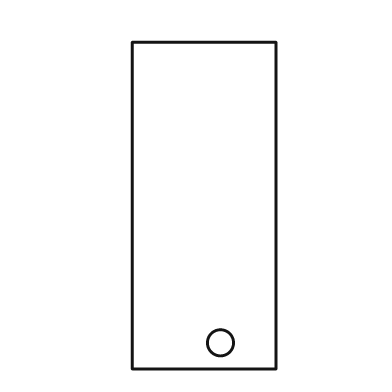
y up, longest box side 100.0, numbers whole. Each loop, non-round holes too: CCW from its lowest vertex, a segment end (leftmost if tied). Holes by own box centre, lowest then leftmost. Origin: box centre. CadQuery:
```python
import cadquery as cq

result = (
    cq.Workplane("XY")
    .moveTo(-22.0, -50.0)
    .lineTo(22.0, -50.0)
    .lineTo(22.0, 50.0)
    .lineTo(-22.0, 50.0)
    .close()
    .moveTo(5.0, -42.0)
    .circle(4.0)
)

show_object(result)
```